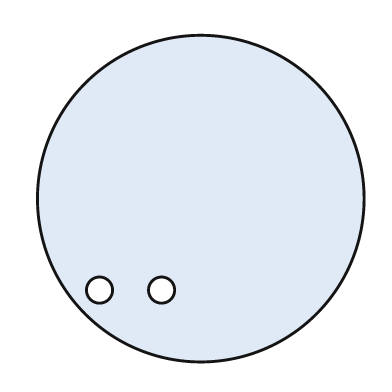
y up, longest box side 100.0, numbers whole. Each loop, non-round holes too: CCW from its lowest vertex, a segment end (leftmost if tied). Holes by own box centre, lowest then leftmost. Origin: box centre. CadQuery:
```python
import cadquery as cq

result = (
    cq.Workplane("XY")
    .moveTo(0.0, 0.0)
    .circle(50.0)
    .moveTo(-31.0, -28.0)
    .circle(4.0)
    .moveTo(-12.0, -28.0)
    .circle(4.0)
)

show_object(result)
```